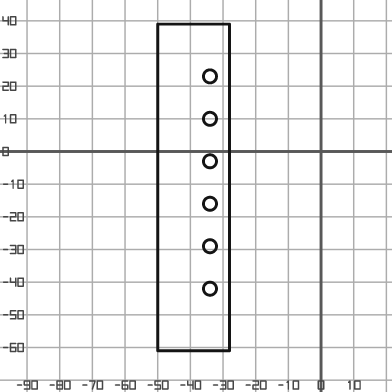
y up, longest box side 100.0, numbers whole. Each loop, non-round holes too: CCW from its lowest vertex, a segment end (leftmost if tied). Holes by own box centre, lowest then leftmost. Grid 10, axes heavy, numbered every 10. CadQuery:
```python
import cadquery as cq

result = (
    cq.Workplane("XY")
    .moveTo(-50.0, -61.0)
    .lineTo(-28.0, -61.0)
    .lineTo(-28.0, 39.0)
    .lineTo(-50.0, 39.0)
    .close()
    .moveTo(-34.0, -42.0)
    .circle(2.0)
    .moveTo(-34.0, -29.0)
    .circle(2.0)
    .moveTo(-34.0, -16.0)
    .circle(2.0)
    .moveTo(-34.0, -3.0)
    .circle(2.0)
    .moveTo(-34.0, 10.0)
    .circle(2.0)
    .moveTo(-34.0, 23.0)
    .circle(2.0)
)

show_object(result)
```